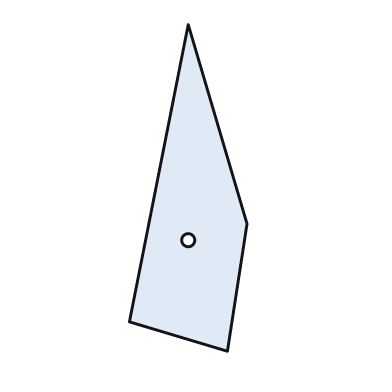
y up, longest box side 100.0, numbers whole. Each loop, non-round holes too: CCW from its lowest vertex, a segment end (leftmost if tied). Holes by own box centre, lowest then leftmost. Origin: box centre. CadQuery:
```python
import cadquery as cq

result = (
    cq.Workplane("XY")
    .moveTo(12.0, -50.0)
    .lineTo(18.0, -11.0)
    .lineTo(0.0, 50.0)
    .lineTo(-18.0, -41.0)
    .close()
    .moveTo(0.0, -16.0)
    .circle(2.0)
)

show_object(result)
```